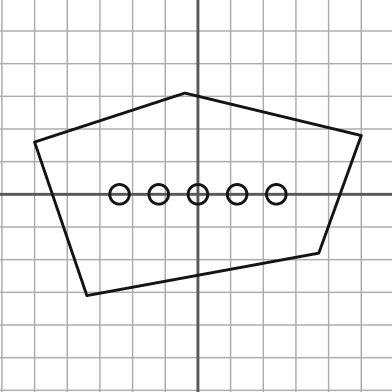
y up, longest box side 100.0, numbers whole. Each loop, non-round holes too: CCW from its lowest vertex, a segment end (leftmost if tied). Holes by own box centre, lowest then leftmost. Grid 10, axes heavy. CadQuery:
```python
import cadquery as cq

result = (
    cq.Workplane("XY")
    .moveTo(-34.0, -31.0)
    .lineTo(37.0, -18.0)
    .lineTo(50.0, 18.0)
    .lineTo(-4.0, 31.0)
    .lineTo(-50.0, 16.0)
    .close()
    .moveTo(-24.0, 0.0)
    .circle(3.0)
    .moveTo(-12.0, 0.0)
    .circle(3.0)
    .moveTo(0.0, 0.0)
    .circle(3.0)
    .moveTo(12.0, 0.0)
    .circle(3.0)
    .moveTo(24.0, 0.0)
    .circle(3.0)
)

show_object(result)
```